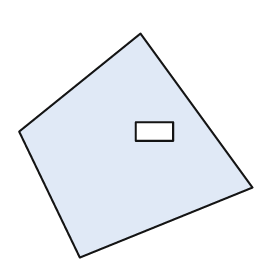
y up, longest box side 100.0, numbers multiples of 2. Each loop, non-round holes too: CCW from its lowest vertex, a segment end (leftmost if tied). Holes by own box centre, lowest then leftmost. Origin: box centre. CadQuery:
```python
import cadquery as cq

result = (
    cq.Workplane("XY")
    .moveTo(-24.0, -48.0)
    .lineTo(50.0, -18.0)
    .lineTo(2.0, 48.0)
    .lineTo(-50.0, 6.0)
    .close()
    .moveTo(0.0, 2.0)
    .lineTo(16.0, 2.0)
    .lineTo(16.0, 10.0)
    .lineTo(0.0, 10.0)
    .close()
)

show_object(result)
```